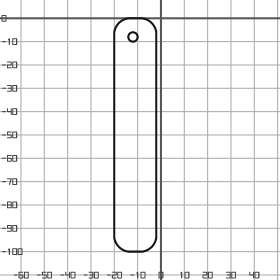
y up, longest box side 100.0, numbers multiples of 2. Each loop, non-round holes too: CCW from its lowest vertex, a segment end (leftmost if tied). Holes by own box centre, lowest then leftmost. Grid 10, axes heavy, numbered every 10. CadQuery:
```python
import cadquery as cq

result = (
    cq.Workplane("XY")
    .moveTo(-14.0, -100.0)
    .lineTo(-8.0, -100.0)
    .threePointArc((-4.0, -98.0), (-2.0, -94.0))
    .lineTo(-2.0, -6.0)
    .threePointArc((-4.0, -2.0), (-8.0, 0.0))
    .lineTo(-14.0, 0.0)
    .threePointArc((-18.0, -2.0), (-20.0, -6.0))
    .lineTo(-20.0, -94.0)
    .threePointArc((-18.0, -98.0), (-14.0, -100.0))
    .close()
    .moveTo(-12.0, -8.0)
    .circle(2.0)
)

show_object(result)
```